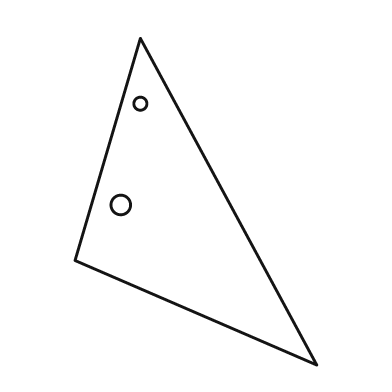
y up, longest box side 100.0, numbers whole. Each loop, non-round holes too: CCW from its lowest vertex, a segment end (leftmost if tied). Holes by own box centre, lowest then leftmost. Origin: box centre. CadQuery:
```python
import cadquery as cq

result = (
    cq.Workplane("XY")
    .moveTo(37.0, -50.0)
    .lineTo(-17.0, 50.0)
    .lineTo(-37.0, -18.0)
    .close()
    .moveTo(-23.0, -1.0)
    .circle(3.0)
    .moveTo(-17.0, 30.0)
    .circle(2.0)
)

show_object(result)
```